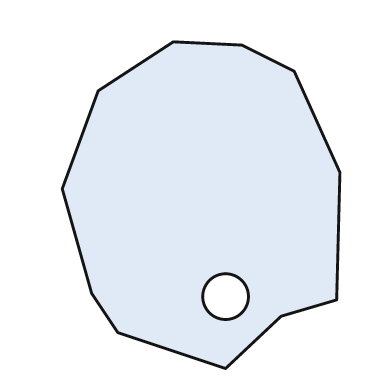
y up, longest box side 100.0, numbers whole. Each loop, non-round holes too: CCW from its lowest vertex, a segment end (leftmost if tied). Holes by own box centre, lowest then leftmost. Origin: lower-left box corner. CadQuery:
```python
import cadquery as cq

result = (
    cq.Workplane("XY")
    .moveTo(50.0, 0.0)
    .lineTo(67.0, 16.0)
    .lineTo(84.0, 21.0)
    .lineTo(85.0, 60.0)
    .lineTo(71.0, 91.0)
    .lineTo(55.0, 99.0)
    .lineTo(34.0, 100.0)
    .lineTo(11.0, 85.0)
    .lineTo(0.0, 55.0)
    .lineTo(9.0, 23.0)
    .lineTo(17.0, 11.0)
    .close()
    .moveTo(50.0, 22.0)
    .circle(7.0)
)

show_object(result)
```